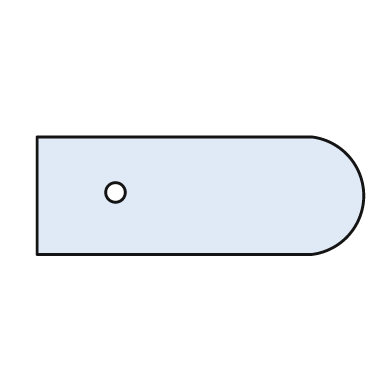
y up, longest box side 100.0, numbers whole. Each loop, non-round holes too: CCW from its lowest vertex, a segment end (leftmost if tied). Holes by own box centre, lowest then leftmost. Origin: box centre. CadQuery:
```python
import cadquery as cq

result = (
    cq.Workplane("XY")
    .moveTo(-50.0, -18.0)
    .lineTo(34.0, -18.0)
    .threePointArc((50.0, 0.0), (34.0, 18.0))
    .lineTo(-50.0, 18.0)
    .close()
    .moveTo(-26.0, 1.0)
    .circle(3.0)
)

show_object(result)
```